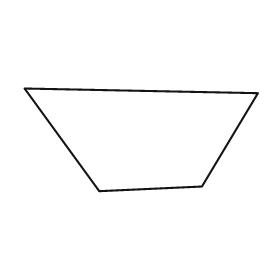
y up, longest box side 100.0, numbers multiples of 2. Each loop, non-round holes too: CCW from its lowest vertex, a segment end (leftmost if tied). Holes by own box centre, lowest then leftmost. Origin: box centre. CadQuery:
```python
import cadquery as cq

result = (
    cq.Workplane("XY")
    .moveTo(-18.0, -22.0)
    .lineTo(26.0, -20.0)
    .lineTo(50.0, 20.0)
    .lineTo(-50.0, 22.0)
    .close()
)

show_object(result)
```